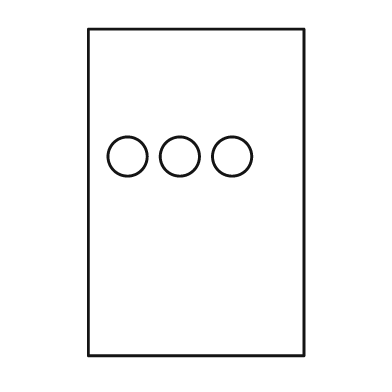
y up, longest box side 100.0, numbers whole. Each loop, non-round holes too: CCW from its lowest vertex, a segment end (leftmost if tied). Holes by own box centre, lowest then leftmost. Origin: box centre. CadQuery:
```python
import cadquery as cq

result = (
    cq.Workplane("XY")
    .moveTo(-33.0, -50.0)
    .lineTo(33.0, -50.0)
    .lineTo(33.0, 50.0)
    .lineTo(-33.0, 50.0)
    .close()
    .moveTo(-21.0, 11.0)
    .circle(6.0)
    .moveTo(-5.0, 11.0)
    .circle(6.0)
    .moveTo(11.0, 11.0)
    .circle(6.0)
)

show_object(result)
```